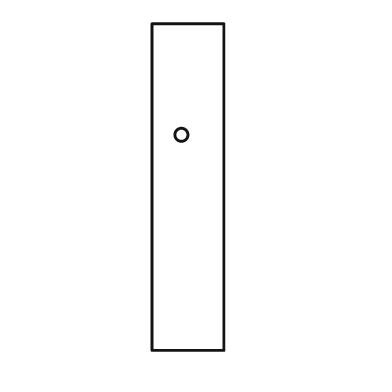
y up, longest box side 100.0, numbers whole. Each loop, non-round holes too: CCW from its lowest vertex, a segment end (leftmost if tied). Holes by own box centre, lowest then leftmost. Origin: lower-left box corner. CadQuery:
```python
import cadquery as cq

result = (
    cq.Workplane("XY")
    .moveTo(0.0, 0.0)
    .lineTo(22.0, 0.0)
    .lineTo(22.0, 100.0)
    .lineTo(0.0, 100.0)
    .close()
    .moveTo(9.0, 66.0)
    .circle(2.0)
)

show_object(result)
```